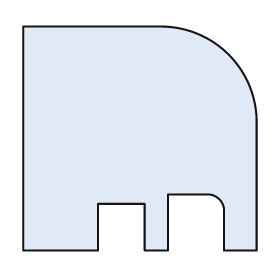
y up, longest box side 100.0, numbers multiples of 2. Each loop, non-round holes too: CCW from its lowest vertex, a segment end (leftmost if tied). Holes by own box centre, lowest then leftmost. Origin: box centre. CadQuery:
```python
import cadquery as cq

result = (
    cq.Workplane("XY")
    .moveTo(-50.0, -48.0)
    .lineTo(-18.0, -48.0)
    .lineTo(-18.0, -28.0)
    .lineTo(2.0, -28.0)
    .lineTo(2.0, -48.0)
    .lineTo(12.0, -48.0)
    .lineTo(12.0, -24.0)
    .lineTo(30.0, -24.0)
    .threePointArc((34.0, -26.0), (36.0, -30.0))
    .lineTo(36.0, -48.0)
    .lineTo(50.0, -48.0)
    .lineTo(50.0, 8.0)
    .threePointArc((38.0, 36.0), (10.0, 48.0))
    .lineTo(-50.0, 48.0)
    .close()
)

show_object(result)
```